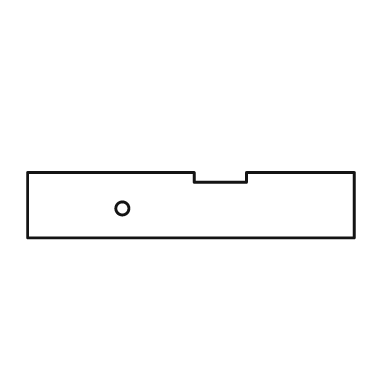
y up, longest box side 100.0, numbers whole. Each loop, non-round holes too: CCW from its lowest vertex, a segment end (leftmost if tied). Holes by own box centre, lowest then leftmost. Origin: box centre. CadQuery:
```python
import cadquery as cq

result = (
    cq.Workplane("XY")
    .moveTo(-50.0, -10.0)
    .lineTo(50.0, -10.0)
    .lineTo(50.0, 10.0)
    .lineTo(17.0, 10.0)
    .lineTo(17.0, 7.0)
    .lineTo(1.0, 7.0)
    .lineTo(1.0, 10.0)
    .lineTo(-50.0, 10.0)
    .close()
    .moveTo(-21.0, -1.0)
    .circle(2.0)
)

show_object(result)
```